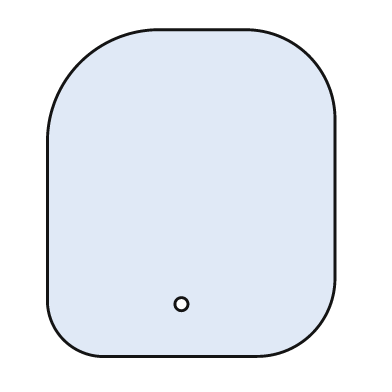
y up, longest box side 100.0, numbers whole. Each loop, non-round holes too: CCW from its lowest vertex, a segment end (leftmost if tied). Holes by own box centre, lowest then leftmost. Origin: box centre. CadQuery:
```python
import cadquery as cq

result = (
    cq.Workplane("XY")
    .moveTo(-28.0, -50.0)
    .lineTo(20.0, -50.0)
    .threePointArc((37.0, -43.0), (44.0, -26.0))
    .lineTo(44.0, 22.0)
    .threePointArc((36.0, 42.0), (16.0, 50.0))
    .lineTo(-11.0, 50.0)
    .threePointArc((-34.0, 40.0), (-44.0, 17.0))
    .lineTo(-44.0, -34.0)
    .threePointArc((-39.0, -45.0), (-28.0, -50.0))
    .close()
    .moveTo(-3.0, -34.0)
    .circle(2.0)
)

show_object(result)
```